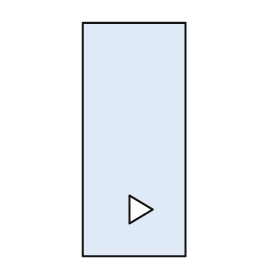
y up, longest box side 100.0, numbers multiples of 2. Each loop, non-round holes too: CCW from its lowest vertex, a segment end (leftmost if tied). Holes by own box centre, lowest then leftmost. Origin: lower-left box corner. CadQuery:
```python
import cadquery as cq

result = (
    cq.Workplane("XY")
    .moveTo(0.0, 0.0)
    .lineTo(44.0, 0.0)
    .lineTo(44.0, 100.0)
    .lineTo(0.0, 100.0)
    .close()
    .moveTo(20.0, 14.0)
    .lineTo(30.0, 20.0)
    .lineTo(20.0, 26.0)
    .close()
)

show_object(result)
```